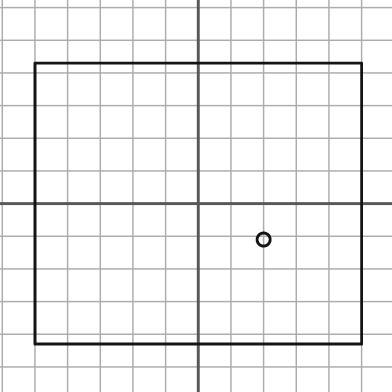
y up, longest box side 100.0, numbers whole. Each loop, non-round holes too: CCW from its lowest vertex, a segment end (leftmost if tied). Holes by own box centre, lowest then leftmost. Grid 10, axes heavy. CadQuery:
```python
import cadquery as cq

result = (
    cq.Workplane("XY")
    .moveTo(-50.0, -43.0)
    .lineTo(50.0, -43.0)
    .lineTo(50.0, 43.0)
    .lineTo(-50.0, 43.0)
    .close()
    .moveTo(20.0, -11.0)
    .circle(2.0)
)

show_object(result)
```